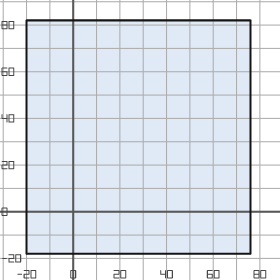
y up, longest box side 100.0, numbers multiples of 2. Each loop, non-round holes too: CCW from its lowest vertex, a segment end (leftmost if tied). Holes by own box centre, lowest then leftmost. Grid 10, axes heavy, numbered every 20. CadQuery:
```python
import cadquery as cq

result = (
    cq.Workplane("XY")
    .moveTo(-20.0, -18.0)
    .lineTo(76.0, -18.0)
    .lineTo(76.0, 82.0)
    .lineTo(-20.0, 82.0)
    .close()
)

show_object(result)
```